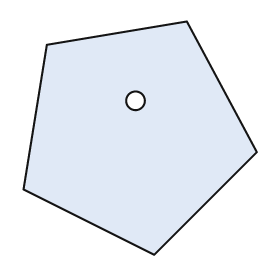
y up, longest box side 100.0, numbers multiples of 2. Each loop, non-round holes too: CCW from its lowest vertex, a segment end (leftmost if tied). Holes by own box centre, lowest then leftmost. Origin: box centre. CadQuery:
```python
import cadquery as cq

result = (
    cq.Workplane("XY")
    .moveTo(6.0, -50.0)
    .lineTo(50.0, -6.0)
    .lineTo(20.0, 50.0)
    .lineTo(-40.0, 40.0)
    .lineTo(-50.0, -22.0)
    .close()
    .moveTo(-2.0, 16.0)
    .circle(4.0)
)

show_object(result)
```